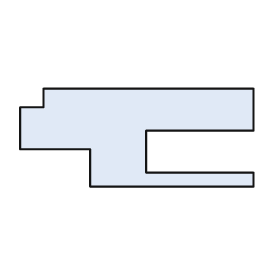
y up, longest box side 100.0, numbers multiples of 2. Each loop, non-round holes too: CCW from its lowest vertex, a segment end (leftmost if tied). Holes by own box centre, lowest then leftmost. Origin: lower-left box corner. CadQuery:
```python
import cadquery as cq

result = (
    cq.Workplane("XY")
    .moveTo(30.0, 0.0)
    .lineTo(100.0, 0.0)
    .lineTo(100.0, 6.0)
    .lineTo(54.0, 6.0)
    .lineTo(54.0, 24.0)
    .lineTo(100.0, 24.0)
    .lineTo(100.0, 42.0)
    .lineTo(10.0, 42.0)
    .lineTo(10.0, 34.0)
    .lineTo(0.0, 34.0)
    .lineTo(0.0, 16.0)
    .lineTo(30.0, 16.0)
    .close()
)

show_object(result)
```